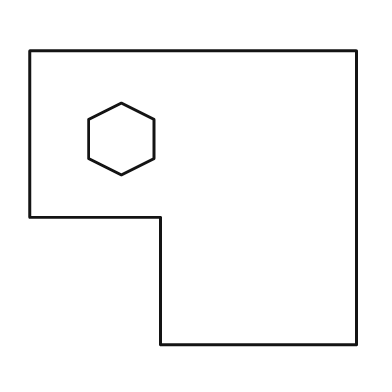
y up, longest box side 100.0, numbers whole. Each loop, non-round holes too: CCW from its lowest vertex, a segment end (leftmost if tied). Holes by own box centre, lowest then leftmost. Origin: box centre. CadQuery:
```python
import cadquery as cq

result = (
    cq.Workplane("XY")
    .moveTo(-10.0, -45.0)
    .lineTo(50.0, -45.0)
    .lineTo(50.0, 45.0)
    .lineTo(-50.0, 45.0)
    .lineTo(-50.0, -6.0)
    .lineTo(-10.0, -6.0)
    .close()
    .moveTo(-22.0, 7.0)
    .lineTo(-12.0, 12.0)
    .lineTo(-12.0, 24.0)
    .lineTo(-22.0, 29.0)
    .lineTo(-32.0, 24.0)
    .lineTo(-32.0, 12.0)
    .close()
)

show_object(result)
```